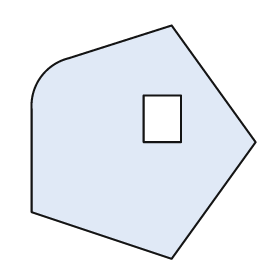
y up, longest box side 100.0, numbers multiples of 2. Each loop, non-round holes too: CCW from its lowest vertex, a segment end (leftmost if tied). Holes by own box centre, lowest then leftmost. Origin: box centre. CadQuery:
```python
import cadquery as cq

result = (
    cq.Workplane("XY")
    .moveTo(12.0, -50.0)
    .lineTo(48.0, 0.0)
    .lineTo(12.0, 50.0)
    .lineTo(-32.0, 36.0)
    .threePointArc((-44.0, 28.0), (-48.0, 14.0))
    .lineTo(-48.0, -30.0)
    .close()
    .moveTo(0.0, 0.0)
    .lineTo(16.0, 0.0)
    .lineTo(16.0, 20.0)
    .lineTo(0.0, 20.0)
    .close()
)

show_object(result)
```